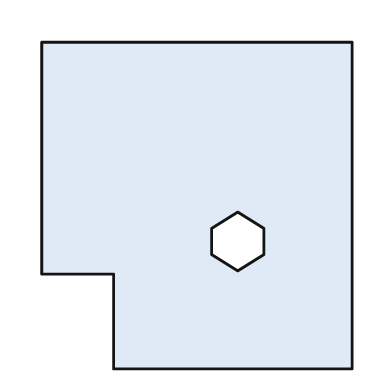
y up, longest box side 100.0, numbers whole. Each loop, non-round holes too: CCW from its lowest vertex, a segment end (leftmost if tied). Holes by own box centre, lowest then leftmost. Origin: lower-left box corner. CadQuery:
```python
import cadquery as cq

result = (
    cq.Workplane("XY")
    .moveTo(22.0, 0.0)
    .lineTo(95.0, 0.0)
    .lineTo(95.0, 100.0)
    .lineTo(0.0, 100.0)
    .lineTo(0.0, 29.0)
    .lineTo(22.0, 29.0)
    .close()
    .moveTo(60.0, 30.0)
    .lineTo(68.0, 35.0)
    .lineTo(68.0, 43.0)
    .lineTo(60.0, 48.0)
    .lineTo(52.0, 43.0)
    .lineTo(52.0, 35.0)
    .close()
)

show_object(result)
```